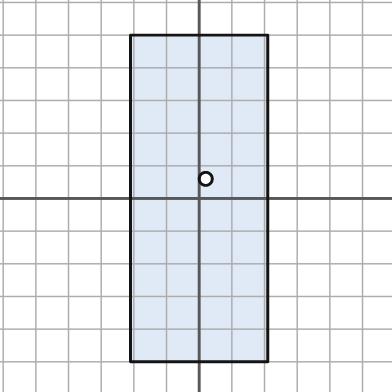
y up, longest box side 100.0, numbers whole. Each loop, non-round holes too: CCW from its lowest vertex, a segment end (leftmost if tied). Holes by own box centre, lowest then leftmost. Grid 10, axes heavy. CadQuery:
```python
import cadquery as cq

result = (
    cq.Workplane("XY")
    .moveTo(-21.0, -50.0)
    .lineTo(21.0, -50.0)
    .lineTo(21.0, 50.0)
    .lineTo(-21.0, 50.0)
    .close()
    .moveTo(2.0, 6.0)
    .circle(2.0)
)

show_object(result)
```